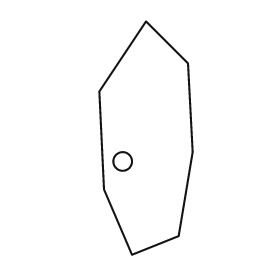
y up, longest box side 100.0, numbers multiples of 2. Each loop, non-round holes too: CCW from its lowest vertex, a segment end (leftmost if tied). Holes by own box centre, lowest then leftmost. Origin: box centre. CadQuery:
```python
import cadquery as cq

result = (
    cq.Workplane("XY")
    .moveTo(-6.0, -50.0)
    .lineTo(14.0, -42.0)
    .lineTo(20.0, -6.0)
    .lineTo(18.0, 32.0)
    .lineTo(0.0, 50.0)
    .lineTo(-20.0, 20.0)
    .lineTo(-18.0, -22.0)
    .close()
    .moveTo(-10.0, -10.0)
    .circle(4.0)
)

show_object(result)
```